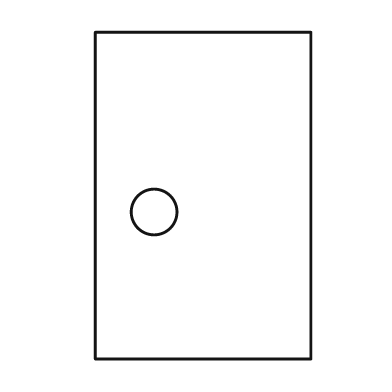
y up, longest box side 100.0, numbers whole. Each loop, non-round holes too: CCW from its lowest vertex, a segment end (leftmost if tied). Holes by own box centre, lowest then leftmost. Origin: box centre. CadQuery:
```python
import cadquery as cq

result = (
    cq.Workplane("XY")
    .moveTo(-33.0, -50.0)
    .lineTo(33.0, -50.0)
    .lineTo(33.0, 50.0)
    .lineTo(-33.0, 50.0)
    .close()
    .moveTo(-15.0, -5.0)
    .circle(7.0)
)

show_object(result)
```